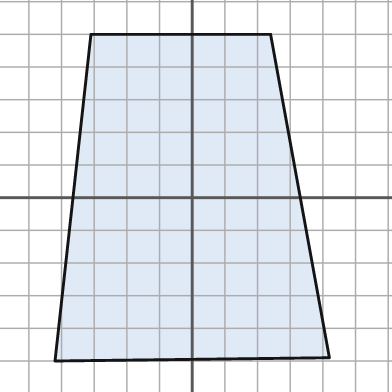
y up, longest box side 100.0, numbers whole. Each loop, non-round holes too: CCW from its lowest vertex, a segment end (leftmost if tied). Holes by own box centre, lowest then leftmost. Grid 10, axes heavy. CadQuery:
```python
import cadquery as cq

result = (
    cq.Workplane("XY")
    .moveTo(-42.0, -50.0)
    .lineTo(42.0, -49.0)
    .lineTo(24.0, 50.0)
    .lineTo(-31.0, 50.0)
    .close()
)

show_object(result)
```